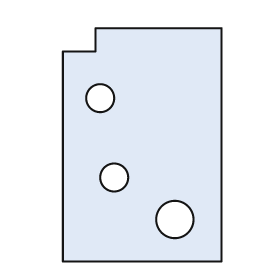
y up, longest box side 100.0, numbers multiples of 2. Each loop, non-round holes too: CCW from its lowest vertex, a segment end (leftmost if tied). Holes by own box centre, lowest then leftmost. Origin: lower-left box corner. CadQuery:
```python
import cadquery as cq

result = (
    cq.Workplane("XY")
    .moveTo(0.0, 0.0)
    .lineTo(68.0, 0.0)
    .lineTo(68.0, 100.0)
    .lineTo(14.0, 100.0)
    .lineTo(14.0, 90.0)
    .lineTo(0.0, 90.0)
    .close()
    .moveTo(48.0, 18.0)
    .circle(8.0)
    .moveTo(22.0, 36.0)
    .circle(6.0)
    .moveTo(16.0, 70.0)
    .circle(6.0)
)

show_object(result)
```